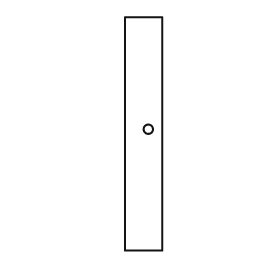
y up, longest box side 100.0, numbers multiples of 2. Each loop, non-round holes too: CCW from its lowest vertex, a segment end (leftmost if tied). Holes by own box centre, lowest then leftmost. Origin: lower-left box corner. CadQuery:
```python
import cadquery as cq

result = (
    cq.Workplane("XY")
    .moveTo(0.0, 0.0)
    .lineTo(16.0, 0.0)
    .lineTo(16.0, 100.0)
    .lineTo(0.0, 100.0)
    .close()
    .moveTo(10.0, 52.0)
    .circle(2.0)
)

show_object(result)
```